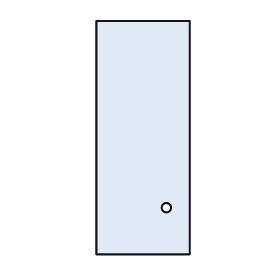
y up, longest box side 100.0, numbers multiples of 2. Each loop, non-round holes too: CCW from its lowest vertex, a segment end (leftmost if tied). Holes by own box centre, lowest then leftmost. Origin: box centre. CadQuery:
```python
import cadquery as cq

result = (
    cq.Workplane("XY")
    .moveTo(-20.0, -50.0)
    .lineTo(20.0, -50.0)
    .lineTo(20.0, 50.0)
    .lineTo(-20.0, 50.0)
    .close()
    .moveTo(10.0, -30.0)
    .circle(2.0)
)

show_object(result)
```